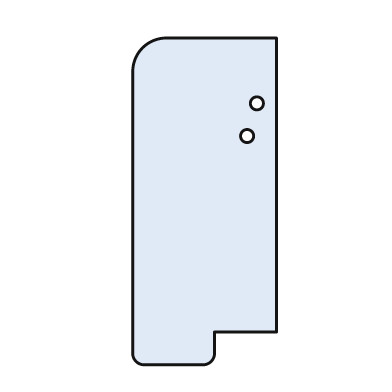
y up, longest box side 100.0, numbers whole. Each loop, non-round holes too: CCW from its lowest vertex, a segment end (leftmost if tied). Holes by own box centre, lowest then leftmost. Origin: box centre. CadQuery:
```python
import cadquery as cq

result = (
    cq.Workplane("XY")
    .moveTo(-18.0, -50.0)
    .lineTo(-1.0, -50.0)
    .threePointArc((2.0, -49.0), (3.0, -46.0))
    .lineTo(3.0, -40.0)
    .lineTo(22.0, -40.0)
    .lineTo(22.0, 50.0)
    .lineTo(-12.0, 50.0)
    .threePointArc((-19.0, 47.0), (-22.0, 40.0))
    .lineTo(-22.0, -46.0)
    .threePointArc((-21.0, -49.0), (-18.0, -50.0))
    .close()
    .moveTo(13.0, 20.0)
    .circle(2.0)
    .moveTo(16.0, 30.0)
    .circle(2.0)
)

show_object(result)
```